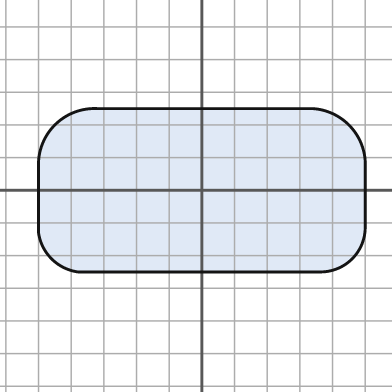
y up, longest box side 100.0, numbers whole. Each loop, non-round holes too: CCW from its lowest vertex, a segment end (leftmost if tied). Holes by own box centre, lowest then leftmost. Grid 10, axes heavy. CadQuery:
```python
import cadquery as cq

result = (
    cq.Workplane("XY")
    .moveTo(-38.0, -25.0)
    .lineTo(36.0, -25.0)
    .threePointArc((46.0, -21.0), (50.0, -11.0))
    .lineTo(50.0, 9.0)
    .threePointArc((45.0, 20.0), (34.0, 25.0))
    .lineTo(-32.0, 25.0)
    .threePointArc((-45.0, 20.0), (-50.0, 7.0))
    .lineTo(-50.0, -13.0)
    .threePointArc((-46.0, -21.0), (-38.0, -25.0))
    .close()
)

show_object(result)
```